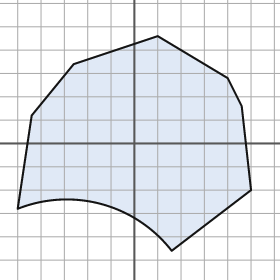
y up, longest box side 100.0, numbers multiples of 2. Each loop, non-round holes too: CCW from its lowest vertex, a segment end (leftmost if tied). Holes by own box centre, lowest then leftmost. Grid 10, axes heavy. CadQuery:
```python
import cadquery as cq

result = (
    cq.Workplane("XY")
    .moveTo(16.0, -46.0)
    .lineTo(50.0, -20.0)
    .lineTo(46.0, 16.0)
    .lineTo(40.0, 28.0)
    .lineTo(10.0, 46.0)
    .lineTo(-26.0, 34.0)
    .lineTo(-44.0, 12.0)
    .lineTo(-50.0, -28.0)
    .threePointArc((-14.0, -26.0), (16.0, -46.0))
    .close()
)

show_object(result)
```